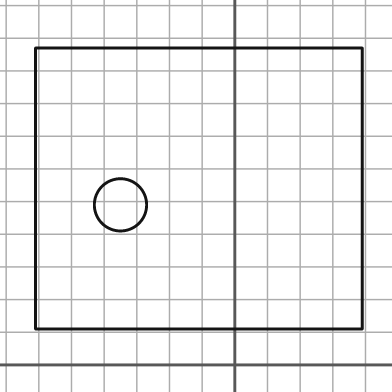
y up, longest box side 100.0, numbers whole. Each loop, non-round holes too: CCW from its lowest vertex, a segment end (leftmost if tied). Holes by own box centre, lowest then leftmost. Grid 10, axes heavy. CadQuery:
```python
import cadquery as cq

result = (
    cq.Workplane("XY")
    .moveTo(-61.0, 11.0)
    .lineTo(39.0, 11.0)
    .lineTo(39.0, 97.0)
    .lineTo(-61.0, 97.0)
    .close()
    .moveTo(-35.0, 49.0)
    .circle(8.0)
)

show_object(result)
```